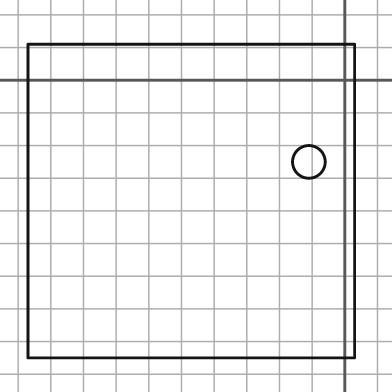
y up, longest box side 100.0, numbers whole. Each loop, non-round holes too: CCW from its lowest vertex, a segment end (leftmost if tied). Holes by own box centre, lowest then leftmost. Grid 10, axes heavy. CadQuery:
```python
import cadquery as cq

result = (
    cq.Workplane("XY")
    .moveTo(-97.0, -85.0)
    .lineTo(3.0, -85.0)
    .lineTo(3.0, 11.0)
    .lineTo(-97.0, 11.0)
    .close()
    .moveTo(-11.0, -25.0)
    .circle(5.0)
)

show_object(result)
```